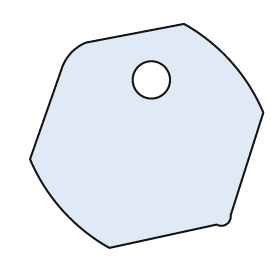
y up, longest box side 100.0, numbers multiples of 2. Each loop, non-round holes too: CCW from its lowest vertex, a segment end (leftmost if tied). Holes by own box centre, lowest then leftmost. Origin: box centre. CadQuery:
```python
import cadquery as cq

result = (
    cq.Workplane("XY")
    .moveTo(-16.0, -48.0)
    .lineTo(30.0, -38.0)
    .threePointArc((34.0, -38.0), (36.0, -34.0))
    .lineTo(50.0, 10.0)
    .threePointArc((36.0, 32.0), (16.0, 48.0))
    .lineTo(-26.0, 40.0)
    .threePointArc((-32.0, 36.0), (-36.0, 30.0))
    .lineTo(-50.0, -10.0)
    .threePointArc((-36.0, -32.0), (-16.0, -48.0))
    .close()
    .moveTo(2.0, 24.0)
    .circle(8.0)
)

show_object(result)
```